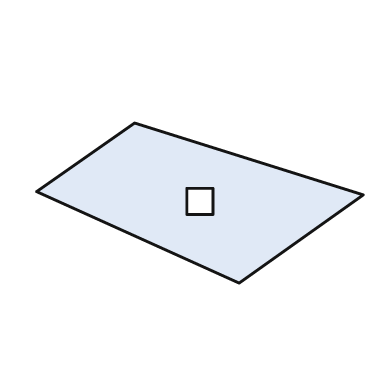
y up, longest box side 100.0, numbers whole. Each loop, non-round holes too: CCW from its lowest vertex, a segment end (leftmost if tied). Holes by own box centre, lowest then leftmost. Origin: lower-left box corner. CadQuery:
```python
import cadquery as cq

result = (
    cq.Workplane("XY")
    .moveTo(62.0, 0.0)
    .lineTo(100.0, 27.0)
    .lineTo(30.0, 49.0)
    .lineTo(0.0, 28.0)
    .close()
    .moveTo(46.0, 21.0)
    .lineTo(54.0, 21.0)
    .lineTo(54.0, 29.0)
    .lineTo(46.0, 29.0)
    .close()
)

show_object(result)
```